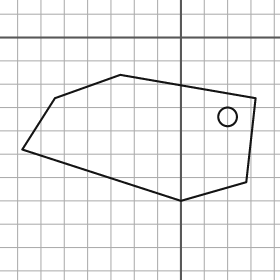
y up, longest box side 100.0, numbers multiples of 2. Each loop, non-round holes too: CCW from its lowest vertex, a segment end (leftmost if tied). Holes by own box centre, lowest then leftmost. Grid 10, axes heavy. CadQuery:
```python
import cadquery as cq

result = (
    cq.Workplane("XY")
    .moveTo(0.0, -70.0)
    .lineTo(28.0, -62.0)
    .lineTo(32.0, -26.0)
    .lineTo(-26.0, -16.0)
    .lineTo(-54.0, -26.0)
    .lineTo(-68.0, -48.0)
    .close()
    .moveTo(20.0, -34.0)
    .circle(4.0)
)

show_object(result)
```